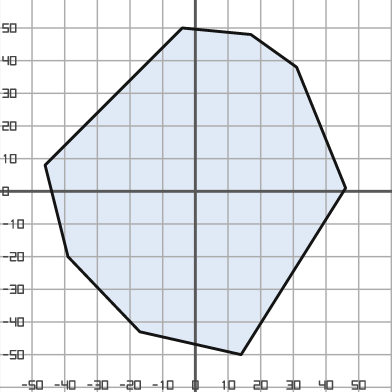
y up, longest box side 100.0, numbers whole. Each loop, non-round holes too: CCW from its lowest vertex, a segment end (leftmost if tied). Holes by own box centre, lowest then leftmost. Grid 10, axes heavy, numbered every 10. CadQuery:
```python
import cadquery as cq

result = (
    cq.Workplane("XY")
    .moveTo(14.0, -50.0)
    .lineTo(46.0, 1.0)
    .lineTo(31.0, 38.0)
    .lineTo(17.0, 48.0)
    .lineTo(-4.0, 50.0)
    .lineTo(-46.0, 8.0)
    .lineTo(-39.0, -20.0)
    .lineTo(-17.0, -43.0)
    .close()
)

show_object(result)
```